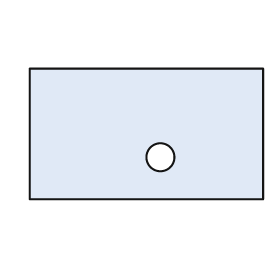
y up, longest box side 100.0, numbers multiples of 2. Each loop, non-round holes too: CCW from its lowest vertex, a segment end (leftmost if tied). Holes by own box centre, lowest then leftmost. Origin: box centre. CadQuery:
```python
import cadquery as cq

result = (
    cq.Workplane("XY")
    .moveTo(-50.0, -28.0)
    .lineTo(50.0, -28.0)
    .lineTo(50.0, 28.0)
    .lineTo(-50.0, 28.0)
    .close()
    .moveTo(6.0, -10.0)
    .circle(6.0)
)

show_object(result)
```